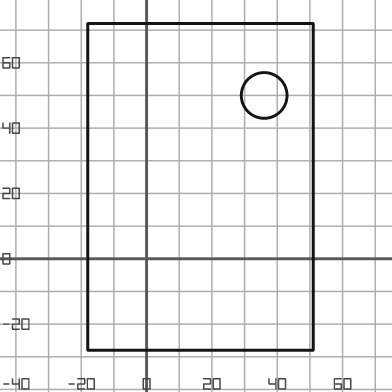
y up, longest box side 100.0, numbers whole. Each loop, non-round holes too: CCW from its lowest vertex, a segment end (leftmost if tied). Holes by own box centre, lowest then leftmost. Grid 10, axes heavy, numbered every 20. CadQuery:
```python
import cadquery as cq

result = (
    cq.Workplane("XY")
    .moveTo(-18.0, -28.0)
    .lineTo(51.0, -28.0)
    .lineTo(51.0, 72.0)
    .lineTo(-18.0, 72.0)
    .close()
    .moveTo(36.0, 50.0)
    .circle(7.0)
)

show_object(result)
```